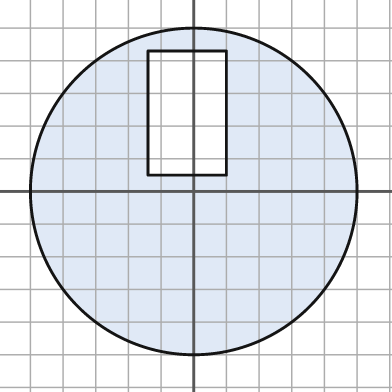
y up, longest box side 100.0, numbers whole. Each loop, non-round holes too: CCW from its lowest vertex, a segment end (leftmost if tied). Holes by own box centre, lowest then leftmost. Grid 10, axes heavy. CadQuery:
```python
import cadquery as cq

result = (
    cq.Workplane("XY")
    .moveTo(0.0, 0.0)
    .circle(50.0)
    .moveTo(-14.0, 5.0)
    .lineTo(10.0, 5.0)
    .lineTo(10.0, 43.0)
    .lineTo(-14.0, 43.0)
    .close()
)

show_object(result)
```